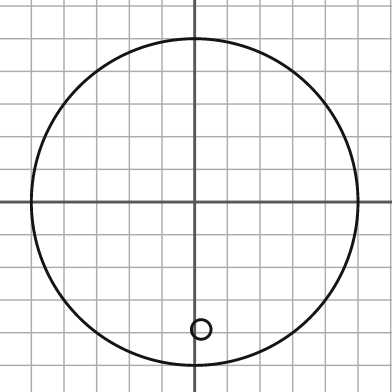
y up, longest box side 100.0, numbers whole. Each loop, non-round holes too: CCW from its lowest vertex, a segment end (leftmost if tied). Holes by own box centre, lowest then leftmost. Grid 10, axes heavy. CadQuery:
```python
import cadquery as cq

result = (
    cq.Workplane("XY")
    .moveTo(0.0, 0.0)
    .circle(50.0)
    .moveTo(2.0, -39.0)
    .circle(3.0)
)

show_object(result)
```